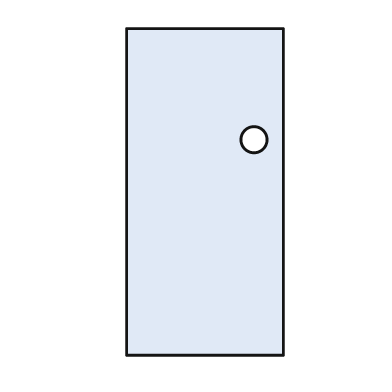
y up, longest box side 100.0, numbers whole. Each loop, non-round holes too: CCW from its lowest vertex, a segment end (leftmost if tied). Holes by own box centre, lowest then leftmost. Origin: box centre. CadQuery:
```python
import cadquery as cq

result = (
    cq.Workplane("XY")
    .moveTo(-24.0, -50.0)
    .lineTo(24.0, -50.0)
    .lineTo(24.0, 50.0)
    .lineTo(-24.0, 50.0)
    .close()
    .moveTo(15.0, 16.0)
    .circle(4.0)
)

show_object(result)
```